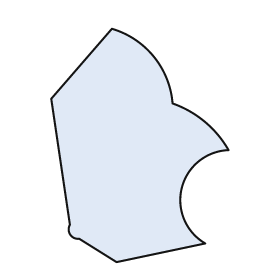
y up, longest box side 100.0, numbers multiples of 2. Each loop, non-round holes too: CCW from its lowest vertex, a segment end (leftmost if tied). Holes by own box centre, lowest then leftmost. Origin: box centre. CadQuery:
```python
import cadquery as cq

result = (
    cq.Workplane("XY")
    .moveTo(-10.0, -50.0)
    .lineTo(28.0, -42.0)
    .threePointArc((18.0, -18.0), (38.0, -2.0))
    .threePointArc((28.0, 10.0), (14.0, 18.0))
    .threePointArc((6.0, 38.0), (-12.0, 50.0))
    .lineTo(-38.0, 20.0)
    .lineTo(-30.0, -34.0)
    .threePointArc((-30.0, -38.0), (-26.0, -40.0))
    .close()
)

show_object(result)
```